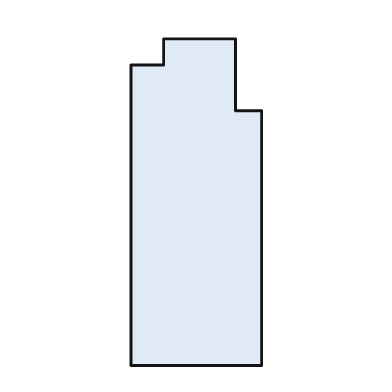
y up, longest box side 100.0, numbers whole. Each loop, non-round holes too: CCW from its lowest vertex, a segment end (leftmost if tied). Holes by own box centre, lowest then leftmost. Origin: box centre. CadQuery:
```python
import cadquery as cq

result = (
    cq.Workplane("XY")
    .moveTo(-20.0, -50.0)
    .lineTo(20.0, -50.0)
    .lineTo(20.0, 28.0)
    .lineTo(12.0, 28.0)
    .lineTo(12.0, 50.0)
    .lineTo(-10.0, 50.0)
    .lineTo(-10.0, 42.0)
    .lineTo(-20.0, 42.0)
    .close()
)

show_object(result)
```